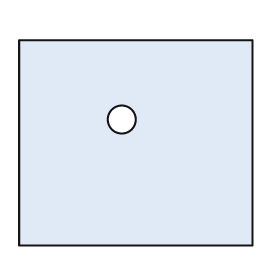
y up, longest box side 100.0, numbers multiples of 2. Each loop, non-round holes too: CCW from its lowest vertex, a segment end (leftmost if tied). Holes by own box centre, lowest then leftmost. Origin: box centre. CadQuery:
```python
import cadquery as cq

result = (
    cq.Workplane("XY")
    .moveTo(-50.0, -44.0)
    .lineTo(50.0, -44.0)
    .lineTo(50.0, 44.0)
    .lineTo(-50.0, 44.0)
    .close()
    .moveTo(-6.0, 10.0)
    .circle(6.0)
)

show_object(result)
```